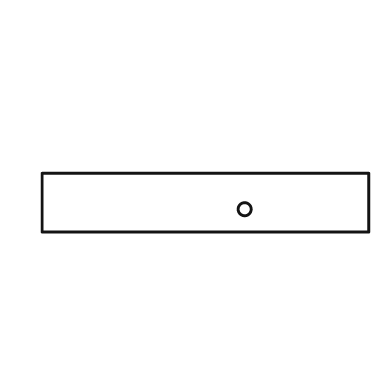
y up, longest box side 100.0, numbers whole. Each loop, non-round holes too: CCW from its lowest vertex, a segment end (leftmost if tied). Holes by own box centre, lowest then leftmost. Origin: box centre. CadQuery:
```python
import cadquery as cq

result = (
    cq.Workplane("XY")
    .moveTo(-50.0, -9.0)
    .lineTo(50.0, -9.0)
    .lineTo(50.0, 9.0)
    .lineTo(-50.0, 9.0)
    .close()
    .moveTo(12.0, -2.0)
    .circle(2.0)
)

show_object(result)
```